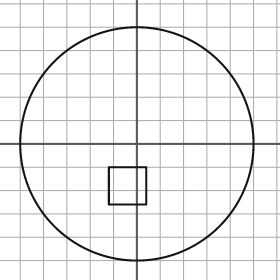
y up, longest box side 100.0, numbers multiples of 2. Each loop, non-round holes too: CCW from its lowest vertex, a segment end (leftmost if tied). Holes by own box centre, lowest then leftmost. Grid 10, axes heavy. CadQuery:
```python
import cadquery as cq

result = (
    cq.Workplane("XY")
    .moveTo(0.0, 0.0)
    .circle(50.0)
    .moveTo(-12.0, -26.0)
    .lineTo(4.0, -26.0)
    .lineTo(4.0, -10.0)
    .lineTo(-12.0, -10.0)
    .close()
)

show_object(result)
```